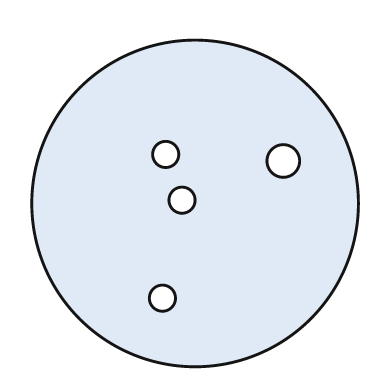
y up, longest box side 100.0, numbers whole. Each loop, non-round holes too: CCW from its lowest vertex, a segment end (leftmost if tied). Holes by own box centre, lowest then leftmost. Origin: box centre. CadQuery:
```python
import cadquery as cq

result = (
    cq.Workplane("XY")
    .moveTo(0.0, 0.0)
    .circle(50.0)
    .moveTo(-10.0, -29.0)
    .circle(4.0)
    .moveTo(-4.0, 1.0)
    .circle(4.0)
    .moveTo(27.0, 13.0)
    .circle(5.0)
    .moveTo(-9.0, 15.0)
    .circle(4.0)
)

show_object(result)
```